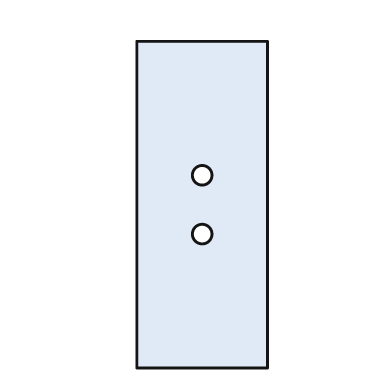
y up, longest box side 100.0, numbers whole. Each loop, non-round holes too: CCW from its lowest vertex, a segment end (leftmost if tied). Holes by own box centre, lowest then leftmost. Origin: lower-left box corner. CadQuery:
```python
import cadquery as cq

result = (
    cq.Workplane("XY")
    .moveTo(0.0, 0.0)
    .lineTo(40.0, 0.0)
    .lineTo(40.0, 100.0)
    .lineTo(0.0, 100.0)
    .close()
    .moveTo(20.0, 41.0)
    .circle(3.0)
    .moveTo(20.0, 59.0)
    .circle(3.0)
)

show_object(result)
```